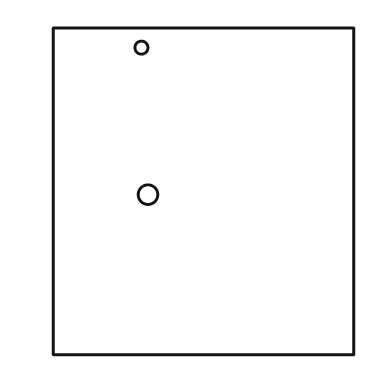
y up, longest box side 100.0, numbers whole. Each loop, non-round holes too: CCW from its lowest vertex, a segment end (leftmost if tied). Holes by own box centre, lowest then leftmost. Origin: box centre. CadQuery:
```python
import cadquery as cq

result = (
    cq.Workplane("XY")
    .moveTo(-46.0, -50.0)
    .lineTo(46.0, -50.0)
    .lineTo(46.0, 50.0)
    .lineTo(-46.0, 50.0)
    .close()
    .moveTo(-17.0, -1.0)
    .circle(3.0)
    .moveTo(-19.0, 44.0)
    .circle(2.0)
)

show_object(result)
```